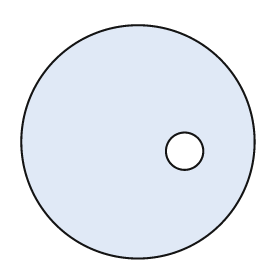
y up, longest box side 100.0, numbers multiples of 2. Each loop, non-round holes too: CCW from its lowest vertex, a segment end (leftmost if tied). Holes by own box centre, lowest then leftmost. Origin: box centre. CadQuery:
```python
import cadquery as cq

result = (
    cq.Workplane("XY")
    .moveTo(0.0, 0.0)
    .circle(50.0)
    .moveTo(20.0, -4.0)
    .circle(8.0)
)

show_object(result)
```